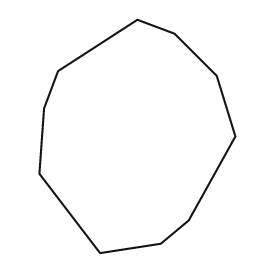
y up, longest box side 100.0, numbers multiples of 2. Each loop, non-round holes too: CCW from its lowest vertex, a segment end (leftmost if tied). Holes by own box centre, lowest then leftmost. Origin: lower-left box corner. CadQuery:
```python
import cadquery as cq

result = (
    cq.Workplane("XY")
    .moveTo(26.0, 0.0)
    .lineTo(52.0, 4.0)
    .lineTo(64.0, 14.0)
    .lineTo(84.0, 50.0)
    .lineTo(76.0, 76.0)
    .lineTo(58.0, 94.0)
    .lineTo(42.0, 100.0)
    .lineTo(8.0, 78.0)
    .lineTo(2.0, 62.0)
    .lineTo(0.0, 34.0)
    .close()
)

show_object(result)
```